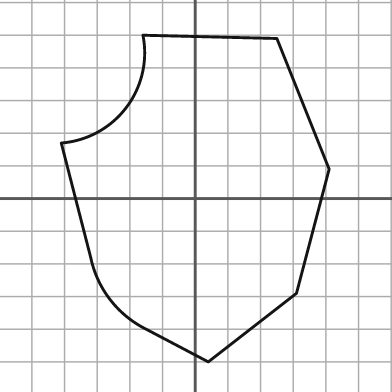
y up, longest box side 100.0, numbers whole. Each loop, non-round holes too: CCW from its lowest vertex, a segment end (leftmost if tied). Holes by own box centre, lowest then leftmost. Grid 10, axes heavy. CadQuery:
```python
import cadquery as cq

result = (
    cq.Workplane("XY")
    .moveTo(4.0, -50.0)
    .lineTo(31.0, -29.0)
    .lineTo(41.0, 9.0)
    .lineTo(25.0, 49.0)
    .lineTo(-16.0, 50.0)
    .threePointArc((-21.0, 28.0), (-41.0, 17.0))
    .lineTo(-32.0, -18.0)
    .threePointArc((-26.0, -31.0), (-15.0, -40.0))
    .close()
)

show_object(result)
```